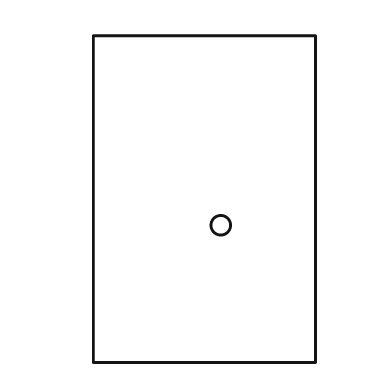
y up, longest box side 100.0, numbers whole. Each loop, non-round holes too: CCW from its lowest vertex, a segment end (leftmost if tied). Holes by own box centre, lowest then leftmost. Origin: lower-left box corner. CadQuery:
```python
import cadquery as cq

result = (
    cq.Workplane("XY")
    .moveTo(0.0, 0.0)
    .lineTo(68.0, 0.0)
    .lineTo(68.0, 100.0)
    .lineTo(0.0, 100.0)
    .close()
    .moveTo(39.0, 42.0)
    .circle(3.0)
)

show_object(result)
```